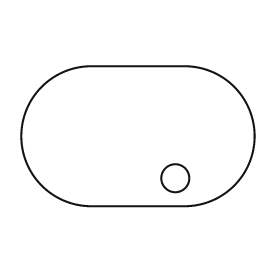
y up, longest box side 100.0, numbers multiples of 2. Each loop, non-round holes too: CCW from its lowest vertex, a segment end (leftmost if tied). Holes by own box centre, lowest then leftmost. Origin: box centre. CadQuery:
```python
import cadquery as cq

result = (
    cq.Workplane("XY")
    .moveTo(-20.0, -30.0)
    .lineTo(20.0, -30.0)
    .threePointArc((50.0, 0.0), (20.0, 30.0))
    .lineTo(-20.0, 30.0)
    .threePointArc((-50.0, 0.0), (-20.0, -30.0))
    .close()
    .moveTo(16.0, -18.0)
    .circle(6.0)
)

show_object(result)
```